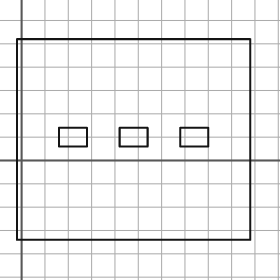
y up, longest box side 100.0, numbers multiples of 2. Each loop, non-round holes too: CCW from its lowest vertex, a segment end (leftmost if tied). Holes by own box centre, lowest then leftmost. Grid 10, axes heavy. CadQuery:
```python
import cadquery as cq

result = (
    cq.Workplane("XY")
    .moveTo(-2.0, -34.0)
    .lineTo(98.0, -34.0)
    .lineTo(98.0, 52.0)
    .lineTo(-2.0, 52.0)
    .close()
    .moveTo(16.0, 6.0)
    .lineTo(28.0, 6.0)
    .lineTo(28.0, 14.0)
    .lineTo(16.0, 14.0)
    .close()
    .moveTo(42.0, 6.0)
    .lineTo(54.0, 6.0)
    .lineTo(54.0, 14.0)
    .lineTo(42.0, 14.0)
    .close()
    .moveTo(68.0, 6.0)
    .lineTo(80.0, 6.0)
    .lineTo(80.0, 14.0)
    .lineTo(68.0, 14.0)
    .close()
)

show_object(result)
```